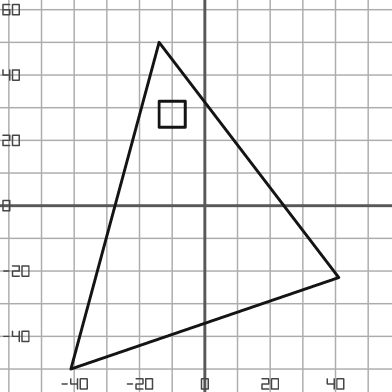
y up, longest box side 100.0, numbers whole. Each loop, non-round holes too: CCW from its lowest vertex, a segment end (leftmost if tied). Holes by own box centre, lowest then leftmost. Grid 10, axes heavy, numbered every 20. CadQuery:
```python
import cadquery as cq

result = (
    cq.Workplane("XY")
    .moveTo(-41.0, -50.0)
    .lineTo(41.0, -22.0)
    .lineTo(-14.0, 50.0)
    .close()
    .moveTo(-14.0, 24.0)
    .lineTo(-6.0, 24.0)
    .lineTo(-6.0, 32.0)
    .lineTo(-14.0, 32.0)
    .close()
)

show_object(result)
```